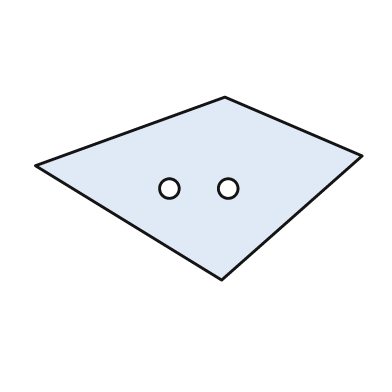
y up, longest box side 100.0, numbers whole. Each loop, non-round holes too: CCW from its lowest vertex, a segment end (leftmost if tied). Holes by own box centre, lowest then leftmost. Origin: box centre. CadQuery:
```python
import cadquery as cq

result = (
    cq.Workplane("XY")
    .moveTo(7.0, -28.0)
    .lineTo(50.0, 10.0)
    .lineTo(8.0, 28.0)
    .lineTo(-50.0, 7.0)
    .close()
    .moveTo(-9.0, 0.0)
    .circle(3.0)
    .moveTo(9.0, 0.0)
    .circle(3.0)
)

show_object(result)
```